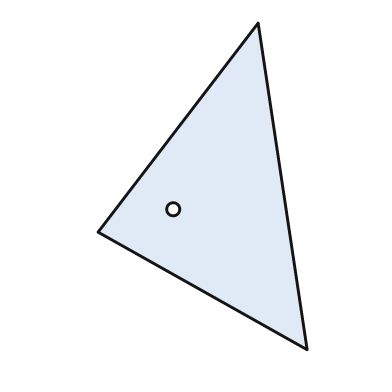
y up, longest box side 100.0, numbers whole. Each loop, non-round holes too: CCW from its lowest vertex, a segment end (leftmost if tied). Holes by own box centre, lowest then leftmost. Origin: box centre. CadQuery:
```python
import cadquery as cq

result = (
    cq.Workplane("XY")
    .moveTo(32.0, -50.0)
    .lineTo(17.0, 50.0)
    .lineTo(-32.0, -14.0)
    .close()
    .moveTo(-9.0, -7.0)
    .circle(2.0)
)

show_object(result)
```